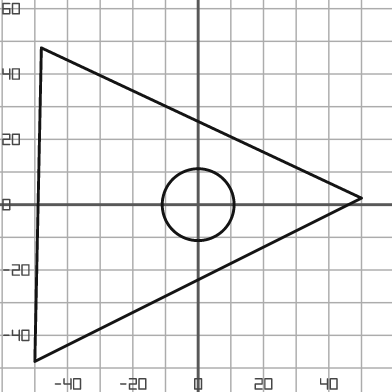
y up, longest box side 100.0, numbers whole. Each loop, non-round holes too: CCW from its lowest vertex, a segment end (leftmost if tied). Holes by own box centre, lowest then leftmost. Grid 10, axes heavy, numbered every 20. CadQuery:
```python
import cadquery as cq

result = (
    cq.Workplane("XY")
    .moveTo(-50.0, -48.0)
    .lineTo(50.0, 2.0)
    .lineTo(-48.0, 48.0)
    .close()
    .moveTo(0.0, 0.0)
    .circle(11.0)
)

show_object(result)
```